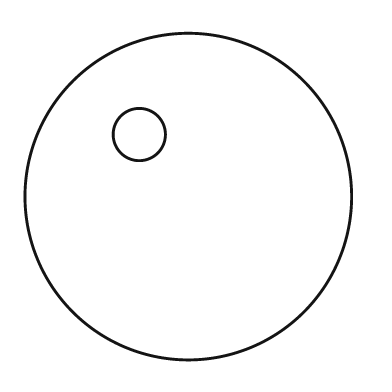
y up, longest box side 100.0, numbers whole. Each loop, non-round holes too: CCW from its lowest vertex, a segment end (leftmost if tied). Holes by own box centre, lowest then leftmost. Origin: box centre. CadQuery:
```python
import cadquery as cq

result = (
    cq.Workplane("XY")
    .moveTo(0.0, 0.0)
    .circle(50.0)
    .moveTo(-15.0, 19.0)
    .circle(8.0)
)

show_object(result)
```